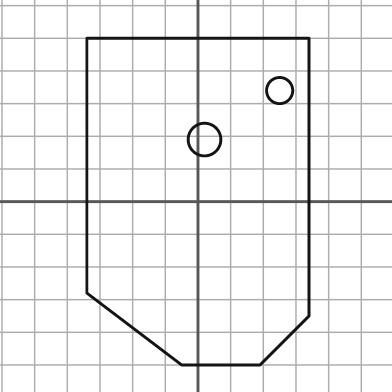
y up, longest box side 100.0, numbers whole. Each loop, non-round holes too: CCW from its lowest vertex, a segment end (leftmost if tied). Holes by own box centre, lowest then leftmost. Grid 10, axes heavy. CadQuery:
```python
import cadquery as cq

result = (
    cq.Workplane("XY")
    .moveTo(-5.0, -50.0)
    .lineTo(19.0, -50.0)
    .lineTo(34.0, -35.0)
    .lineTo(34.0, 50.0)
    .lineTo(-34.0, 50.0)
    .lineTo(-34.0, -28.0)
    .close()
    .moveTo(2.0, 19.0)
    .circle(5.0)
    .moveTo(25.0, 34.0)
    .circle(4.0)
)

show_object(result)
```